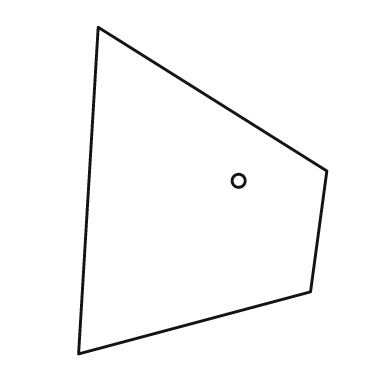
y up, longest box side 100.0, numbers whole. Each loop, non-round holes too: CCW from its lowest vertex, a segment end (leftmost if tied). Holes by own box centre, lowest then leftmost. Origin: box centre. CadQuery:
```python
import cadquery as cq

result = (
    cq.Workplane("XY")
    .moveTo(-38.0, -50.0)
    .lineTo(33.0, -31.0)
    .lineTo(38.0, 6.0)
    .lineTo(-32.0, 50.0)
    .close()
    .moveTo(11.0, 3.0)
    .circle(2.0)
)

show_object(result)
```